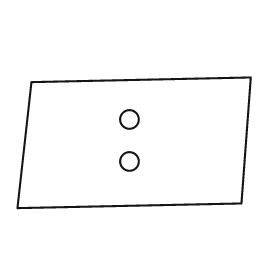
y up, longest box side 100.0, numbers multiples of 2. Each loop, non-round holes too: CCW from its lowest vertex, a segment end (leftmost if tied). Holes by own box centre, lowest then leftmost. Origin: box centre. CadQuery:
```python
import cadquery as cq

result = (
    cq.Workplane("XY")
    .moveTo(-50.0, -28.0)
    .lineTo(46.0, -26.0)
    .lineTo(50.0, 28.0)
    .lineTo(-44.0, 26.0)
    .close()
    .moveTo(-2.0, -8.0)
    .circle(4.0)
    .moveTo(-2.0, 10.0)
    .circle(4.0)
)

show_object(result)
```